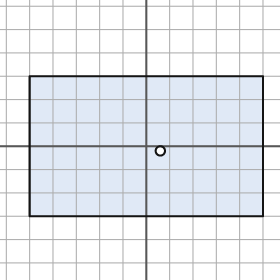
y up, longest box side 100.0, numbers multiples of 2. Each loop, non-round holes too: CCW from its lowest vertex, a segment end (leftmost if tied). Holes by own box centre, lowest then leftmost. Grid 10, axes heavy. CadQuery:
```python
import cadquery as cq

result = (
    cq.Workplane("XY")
    .moveTo(-50.0, -30.0)
    .lineTo(50.0, -30.0)
    .lineTo(50.0, 30.0)
    .lineTo(-50.0, 30.0)
    .close()
    .moveTo(6.0, -2.0)
    .circle(2.0)
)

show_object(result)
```